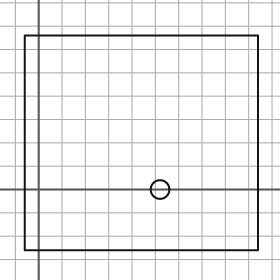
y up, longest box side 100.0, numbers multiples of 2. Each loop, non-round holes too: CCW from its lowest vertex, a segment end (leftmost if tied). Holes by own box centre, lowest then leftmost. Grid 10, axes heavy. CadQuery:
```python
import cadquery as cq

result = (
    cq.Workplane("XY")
    .moveTo(-6.0, -26.0)
    .lineTo(94.0, -26.0)
    .lineTo(94.0, 66.0)
    .lineTo(-6.0, 66.0)
    .close()
    .moveTo(52.0, 0.0)
    .circle(4.0)
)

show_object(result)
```